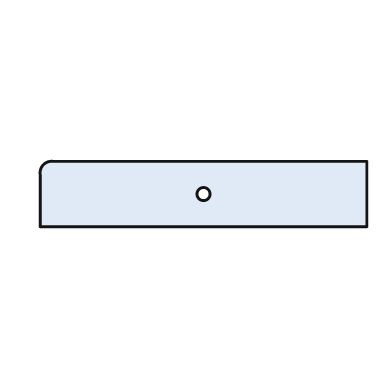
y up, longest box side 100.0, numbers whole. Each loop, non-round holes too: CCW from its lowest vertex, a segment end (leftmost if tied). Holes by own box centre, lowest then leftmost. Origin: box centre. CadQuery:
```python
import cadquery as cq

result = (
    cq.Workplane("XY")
    .moveTo(-50.0, -10.0)
    .lineTo(50.0, -10.0)
    .lineTo(50.0, 10.0)
    .lineTo(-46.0, 10.0)
    .threePointArc((-49.0, 9.0), (-50.0, 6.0))
    .close()
    .moveTo(0.0, 0.0)
    .circle(2.0)
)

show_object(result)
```